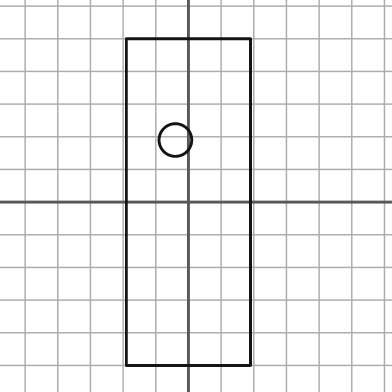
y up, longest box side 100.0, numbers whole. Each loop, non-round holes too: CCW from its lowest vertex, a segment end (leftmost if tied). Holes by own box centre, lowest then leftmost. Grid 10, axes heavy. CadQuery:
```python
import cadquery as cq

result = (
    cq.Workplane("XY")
    .moveTo(-19.0, -50.0)
    .lineTo(19.0, -50.0)
    .lineTo(19.0, 50.0)
    .lineTo(-19.0, 50.0)
    .close()
    .moveTo(-4.0, 19.0)
    .circle(5.0)
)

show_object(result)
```